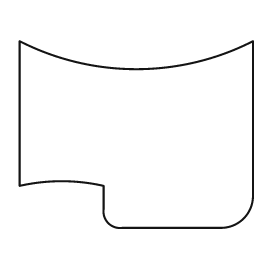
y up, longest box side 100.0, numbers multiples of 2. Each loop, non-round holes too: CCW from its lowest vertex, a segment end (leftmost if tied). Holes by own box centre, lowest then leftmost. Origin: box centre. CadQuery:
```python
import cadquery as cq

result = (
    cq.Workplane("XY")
    .moveTo(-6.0, -40.0)
    .lineTo(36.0, -40.0)
    .threePointArc((46.0, -36.0), (50.0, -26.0))
    .lineTo(50.0, 40.0)
    .threePointArc((0.0, 28.0), (-50.0, 40.0))
    .lineTo(-50.0, -22.0)
    .threePointArc((-32.0, -20.0), (-14.0, -22.0))
    .lineTo(-14.0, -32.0)
    .threePointArc((-12.0, -38.0), (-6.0, -40.0))
    .close()
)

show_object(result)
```